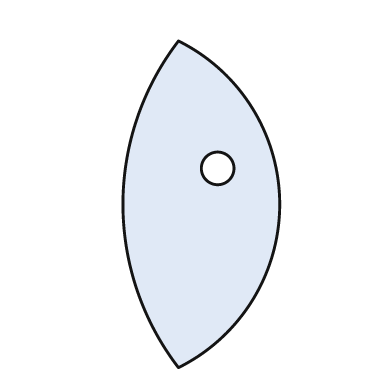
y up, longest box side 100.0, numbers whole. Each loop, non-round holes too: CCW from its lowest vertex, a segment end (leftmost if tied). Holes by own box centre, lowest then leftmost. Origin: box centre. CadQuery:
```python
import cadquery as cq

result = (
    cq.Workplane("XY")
    .moveTo(-7.0, -50.0)
    .threePointArc((24.0, 0.0), (-7.0, 50.0))
    .threePointArc((-24.0, 0.0), (-7.0, -50.0))
    .close()
    .moveTo(5.0, 11.0)
    .circle(5.0)
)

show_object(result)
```